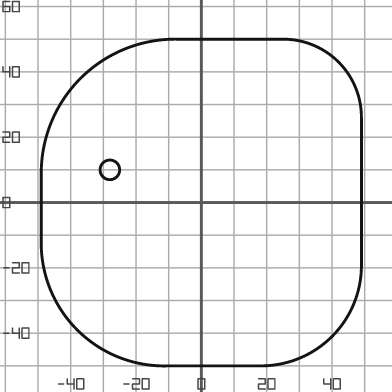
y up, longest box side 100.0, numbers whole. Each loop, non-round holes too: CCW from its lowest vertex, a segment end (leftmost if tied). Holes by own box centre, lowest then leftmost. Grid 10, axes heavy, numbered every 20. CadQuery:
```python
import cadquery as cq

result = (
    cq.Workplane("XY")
    .moveTo(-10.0, -50.0)
    .lineTo(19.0, -50.0)
    .threePointArc((40.0, -41.0), (49.0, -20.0))
    .lineTo(49.0, 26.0)
    .threePointArc((42.0, 43.0), (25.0, 50.0))
    .lineTo(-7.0, 50.0)
    .threePointArc((-37.0, 38.0), (-49.0, 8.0))
    .lineTo(-49.0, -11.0)
    .threePointArc((-38.0, -39.0), (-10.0, -50.0))
    .close()
    .moveTo(-28.0, 10.0)
    .circle(3.0)
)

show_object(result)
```